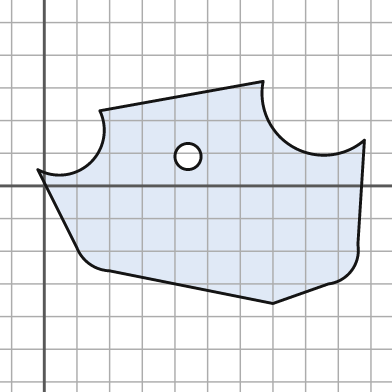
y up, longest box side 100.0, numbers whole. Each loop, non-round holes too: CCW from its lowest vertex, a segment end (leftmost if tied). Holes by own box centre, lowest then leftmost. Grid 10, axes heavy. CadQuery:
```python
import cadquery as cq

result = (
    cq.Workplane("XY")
    .moveTo(70.0, -36.0)
    .lineTo(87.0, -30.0)
    .threePointArc((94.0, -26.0), (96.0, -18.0))
    .lineTo(98.0, 14.0)
    .threePointArc((76.0, 12.0), (67.0, 32.0))
    .lineTo(17.0, 23.0)
    .threePointArc((14.0, 7.0), (-2.0, 5.0))
    .lineTo(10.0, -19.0)
    .threePointArc((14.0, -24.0), (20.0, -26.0))
    .close()
    .moveTo(44.0, 9.0)
    .circle(4.0)
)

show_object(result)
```